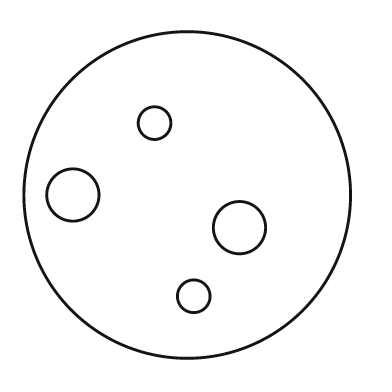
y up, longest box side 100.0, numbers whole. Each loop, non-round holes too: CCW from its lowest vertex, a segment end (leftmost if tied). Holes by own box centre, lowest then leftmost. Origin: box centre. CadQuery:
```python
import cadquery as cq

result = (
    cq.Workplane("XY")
    .moveTo(0.0, 0.0)
    .circle(50.0)
    .moveTo(2.0, -31.0)
    .circle(5.0)
    .moveTo(16.0, -10.0)
    .circle(8.0)
    .moveTo(-35.0, 0.0)
    .circle(8.0)
    .moveTo(-10.0, 22.0)
    .circle(5.0)
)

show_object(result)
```